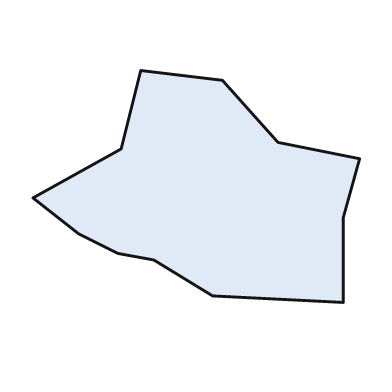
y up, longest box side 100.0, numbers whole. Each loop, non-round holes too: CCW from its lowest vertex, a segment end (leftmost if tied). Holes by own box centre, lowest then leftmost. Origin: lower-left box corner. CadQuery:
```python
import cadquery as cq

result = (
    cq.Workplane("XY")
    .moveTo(95.0, 0.0)
    .lineTo(95.0, 26.0)
    .lineTo(100.0, 44.0)
    .lineTo(75.0, 49.0)
    .lineTo(58.0, 68.0)
    .lineTo(33.0, 71.0)
    .lineTo(27.0, 47.0)
    .lineTo(0.0, 32.0)
    .lineTo(14.0, 21.0)
    .lineTo(26.0, 15.0)
    .lineTo(37.0, 13.0)
    .lineTo(55.0, 2.0)
    .close()
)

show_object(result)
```